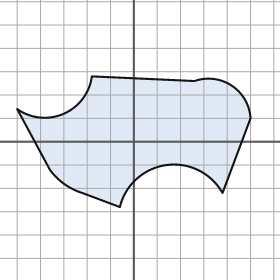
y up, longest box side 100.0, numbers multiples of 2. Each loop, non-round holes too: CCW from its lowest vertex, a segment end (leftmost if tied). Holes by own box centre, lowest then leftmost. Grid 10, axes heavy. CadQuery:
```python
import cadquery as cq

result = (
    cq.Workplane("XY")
    .moveTo(-6.0, -28.0)
    .threePointArc((14.0, -10.0), (38.0, -22.0))
    .lineTo(50.0, 10.0)
    .threePointArc((42.0, 24.0), (26.0, 26.0))
    .lineTo(-18.0, 28.0)
    .threePointArc((-30.0, 12.0), (-50.0, 14.0))
    .lineTo(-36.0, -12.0)
    .threePointArc((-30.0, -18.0), (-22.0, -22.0))
    .close()
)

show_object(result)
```